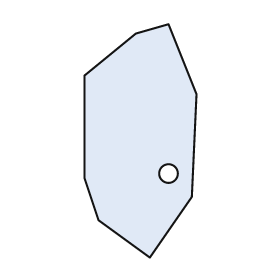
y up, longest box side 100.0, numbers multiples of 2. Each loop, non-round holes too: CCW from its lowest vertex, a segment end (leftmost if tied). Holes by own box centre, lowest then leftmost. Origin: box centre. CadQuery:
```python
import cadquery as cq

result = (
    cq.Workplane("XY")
    .moveTo(4.0, -50.0)
    .lineTo(22.0, -24.0)
    .lineTo(24.0, 20.0)
    .lineTo(12.0, 50.0)
    .lineTo(-2.0, 46.0)
    .lineTo(-24.0, 28.0)
    .lineTo(-24.0, -16.0)
    .lineTo(-18.0, -34.0)
    .close()
    .moveTo(12.0, -14.0)
    .circle(4.0)
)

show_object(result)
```